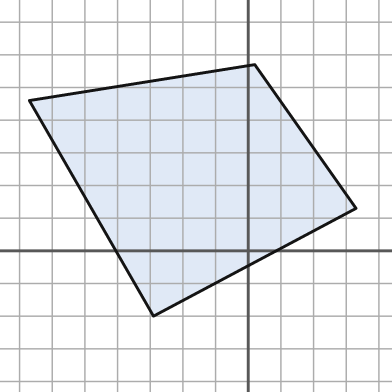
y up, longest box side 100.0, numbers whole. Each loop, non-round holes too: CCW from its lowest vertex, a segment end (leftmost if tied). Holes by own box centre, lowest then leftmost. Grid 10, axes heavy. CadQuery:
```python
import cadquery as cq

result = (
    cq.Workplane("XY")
    .moveTo(-29.0, -20.0)
    .lineTo(33.0, 13.0)
    .lineTo(2.0, 57.0)
    .lineTo(-67.0, 46.0)
    .close()
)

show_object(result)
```